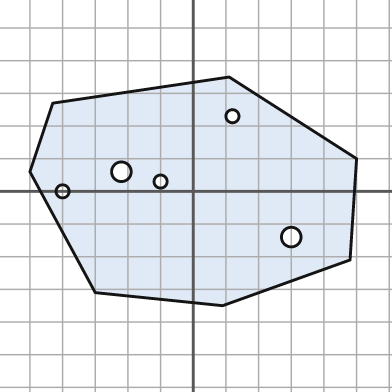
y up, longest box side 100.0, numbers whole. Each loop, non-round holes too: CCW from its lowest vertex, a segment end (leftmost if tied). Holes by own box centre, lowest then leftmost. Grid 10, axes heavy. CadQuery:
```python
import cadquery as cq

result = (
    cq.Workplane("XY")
    .moveTo(9.0, -35.0)
    .lineTo(48.0, -21.0)
    .lineTo(50.0, 10.0)
    .lineTo(11.0, 35.0)
    .lineTo(-43.0, 27.0)
    .lineTo(-50.0, 6.0)
    .lineTo(-30.0, -31.0)
    .close()
    .moveTo(30.0, -14.0)
    .circle(3.0)
    .moveTo(-40.0, 0.0)
    .circle(2.0)
    .moveTo(-10.0, 3.0)
    .circle(2.0)
    .moveTo(-22.0, 6.0)
    .circle(3.0)
    .moveTo(12.0, 23.0)
    .circle(2.0)
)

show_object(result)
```